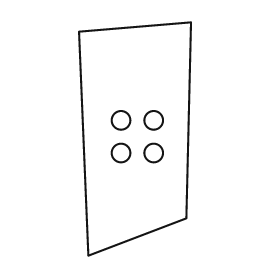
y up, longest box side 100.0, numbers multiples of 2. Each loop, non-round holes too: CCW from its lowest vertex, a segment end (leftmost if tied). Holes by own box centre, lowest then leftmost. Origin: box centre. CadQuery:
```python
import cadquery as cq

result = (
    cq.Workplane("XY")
    .moveTo(-20.0, -50.0)
    .lineTo(22.0, -34.0)
    .lineTo(24.0, 50.0)
    .lineTo(-24.0, 46.0)
    .close()
    .moveTo(-6.0, -6.0)
    .circle(4.0)
    .moveTo(8.0, -6.0)
    .circle(4.0)
    .moveTo(-6.0, 8.0)
    .circle(4.0)
    .moveTo(8.0, 8.0)
    .circle(4.0)
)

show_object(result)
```